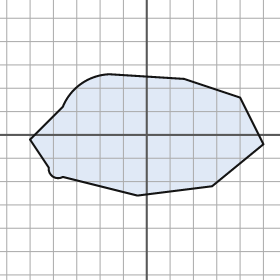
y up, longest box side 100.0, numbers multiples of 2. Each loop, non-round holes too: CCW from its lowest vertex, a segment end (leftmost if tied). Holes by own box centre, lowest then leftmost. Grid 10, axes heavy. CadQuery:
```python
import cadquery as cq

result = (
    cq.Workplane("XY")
    .moveTo(-4.0, -26.0)
    .lineTo(28.0, -22.0)
    .lineTo(50.0, -4.0)
    .lineTo(40.0, 16.0)
    .lineTo(16.0, 24.0)
    .lineTo(-16.0, 26.0)
    .threePointArc((-28.0, 22.0), (-36.0, 12.0))
    .lineTo(-50.0, -2.0)
    .lineTo(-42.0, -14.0)
    .threePointArc((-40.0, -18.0), (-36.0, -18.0))
    .close()
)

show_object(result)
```